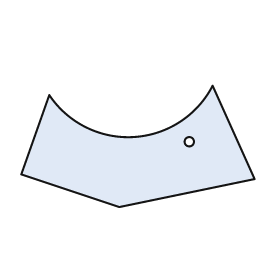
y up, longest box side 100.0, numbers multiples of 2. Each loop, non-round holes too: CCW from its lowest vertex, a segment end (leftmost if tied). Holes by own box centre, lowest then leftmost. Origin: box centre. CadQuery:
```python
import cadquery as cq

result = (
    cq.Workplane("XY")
    .moveTo(-8.0, -26.0)
    .lineTo(50.0, -14.0)
    .lineTo(32.0, 26.0)
    .threePointArc((-2.0, 4.0), (-38.0, 22.0))
    .lineTo(-50.0, -12.0)
    .close()
    .moveTo(22.0, 2.0)
    .circle(2.0)
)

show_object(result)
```